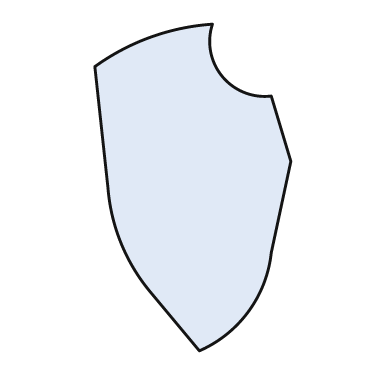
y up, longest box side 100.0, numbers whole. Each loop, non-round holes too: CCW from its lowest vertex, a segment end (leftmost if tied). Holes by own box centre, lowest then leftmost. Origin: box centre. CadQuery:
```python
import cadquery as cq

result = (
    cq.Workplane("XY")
    .moveTo(2.0, -50.0)
    .threePointArc((17.0, -38.0), (24.0, -20.0))
    .lineTo(30.0, 8.0)
    .lineTo(24.0, 28.0)
    .threePointArc((9.0, 34.0), (6.0, 50.0))
    .threePointArc((-13.0, 46.0), (-30.0, 37.0))
    .lineTo(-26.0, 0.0)
    .threePointArc((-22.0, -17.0), (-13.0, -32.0))
    .close()
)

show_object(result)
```